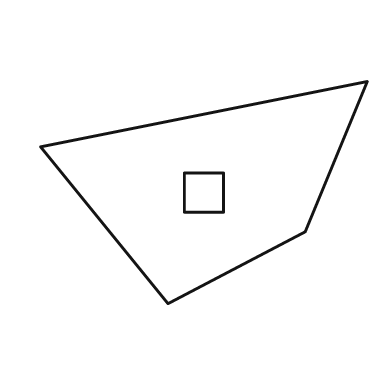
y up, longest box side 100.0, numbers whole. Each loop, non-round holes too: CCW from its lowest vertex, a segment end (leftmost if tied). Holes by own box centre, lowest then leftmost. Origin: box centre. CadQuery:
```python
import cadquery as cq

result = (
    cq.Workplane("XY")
    .moveTo(-11.0, -34.0)
    .lineTo(31.0, -12.0)
    .lineTo(50.0, 34.0)
    .lineTo(-50.0, 14.0)
    .close()
    .moveTo(-6.0, -6.0)
    .lineTo(6.0, -6.0)
    .lineTo(6.0, 6.0)
    .lineTo(-6.0, 6.0)
    .close()
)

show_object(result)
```